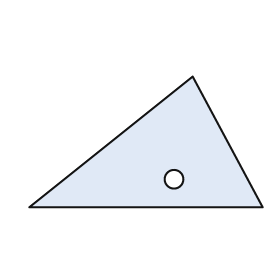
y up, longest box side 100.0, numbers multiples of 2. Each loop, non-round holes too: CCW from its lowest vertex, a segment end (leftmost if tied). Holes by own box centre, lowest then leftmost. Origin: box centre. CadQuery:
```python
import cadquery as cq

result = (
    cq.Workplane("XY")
    .moveTo(-50.0, -28.0)
    .lineTo(50.0, -28.0)
    .lineTo(20.0, 28.0)
    .close()
    .moveTo(12.0, -16.0)
    .circle(4.0)
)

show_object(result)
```